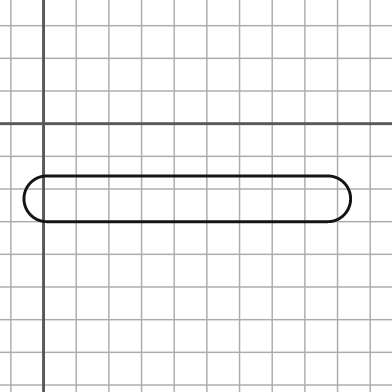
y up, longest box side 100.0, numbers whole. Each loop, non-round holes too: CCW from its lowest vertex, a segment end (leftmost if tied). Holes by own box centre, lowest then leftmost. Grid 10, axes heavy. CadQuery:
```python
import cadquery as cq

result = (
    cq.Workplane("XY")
    .moveTo(1.0, -30.0)
    .lineTo(87.0, -30.0)
    .threePointArc((94.0, -23.0), (87.0, -16.0))
    .lineTo(1.0, -16.0)
    .threePointArc((-6.0, -23.0), (1.0, -30.0))
    .close()
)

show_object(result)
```